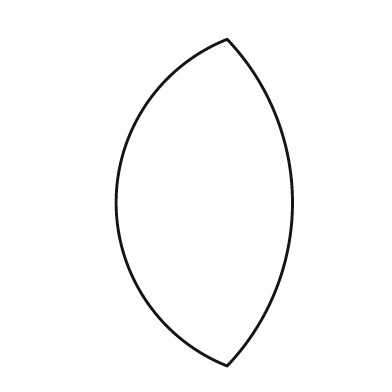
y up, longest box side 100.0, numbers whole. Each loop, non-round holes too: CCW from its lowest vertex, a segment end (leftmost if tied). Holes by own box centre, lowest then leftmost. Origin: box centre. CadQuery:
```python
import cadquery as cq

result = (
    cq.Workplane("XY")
    .moveTo(7.0, -50.0)
    .threePointArc((27.0, 0.0), (7.0, 50.0))
    .threePointArc((-27.0, 0.0), (7.0, -50.0))
    .close()
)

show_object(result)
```